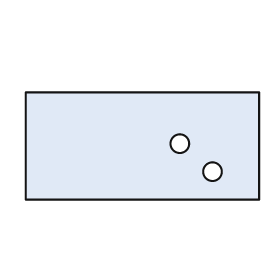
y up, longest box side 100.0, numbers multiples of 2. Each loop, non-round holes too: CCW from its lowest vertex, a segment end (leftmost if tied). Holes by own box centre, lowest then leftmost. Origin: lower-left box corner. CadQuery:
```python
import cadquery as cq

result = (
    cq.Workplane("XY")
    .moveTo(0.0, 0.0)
    .lineTo(100.0, 0.0)
    .lineTo(100.0, 46.0)
    .lineTo(0.0, 46.0)
    .close()
    .moveTo(80.0, 12.0)
    .circle(4.0)
    .moveTo(66.0, 24.0)
    .circle(4.0)
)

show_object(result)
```